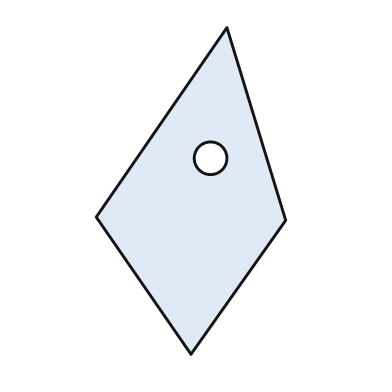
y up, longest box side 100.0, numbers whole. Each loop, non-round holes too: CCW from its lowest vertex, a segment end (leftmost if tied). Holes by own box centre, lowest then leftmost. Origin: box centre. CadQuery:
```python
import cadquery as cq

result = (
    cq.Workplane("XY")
    .moveTo(0.0, -50.0)
    .lineTo(29.0, -9.0)
    .lineTo(11.0, 50.0)
    .lineTo(-29.0, -8.0)
    .close()
    .moveTo(6.0, 10.0)
    .circle(5.0)
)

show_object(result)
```